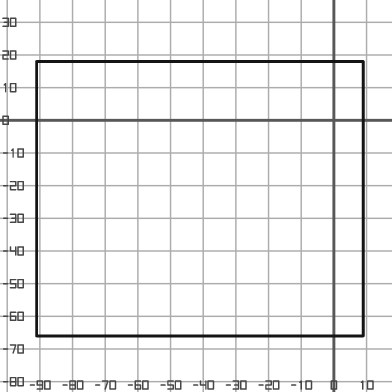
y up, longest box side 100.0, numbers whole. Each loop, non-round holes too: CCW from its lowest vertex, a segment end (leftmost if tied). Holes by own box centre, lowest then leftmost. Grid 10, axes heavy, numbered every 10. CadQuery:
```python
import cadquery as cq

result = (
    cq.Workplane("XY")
    .moveTo(-91.0, -66.0)
    .lineTo(9.0, -66.0)
    .lineTo(9.0, 18.0)
    .lineTo(-91.0, 18.0)
    .close()
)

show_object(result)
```